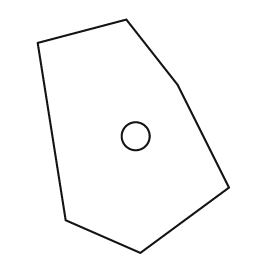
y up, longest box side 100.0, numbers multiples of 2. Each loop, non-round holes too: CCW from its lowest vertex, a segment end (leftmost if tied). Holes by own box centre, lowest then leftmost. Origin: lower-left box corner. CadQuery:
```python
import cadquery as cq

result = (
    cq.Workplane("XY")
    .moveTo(44.0, 0.0)
    .lineTo(82.0, 28.0)
    .lineTo(60.0, 72.0)
    .lineTo(38.0, 100.0)
    .lineTo(0.0, 90.0)
    .lineTo(12.0, 14.0)
    .close()
    .moveTo(42.0, 50.0)
    .circle(6.0)
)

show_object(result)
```